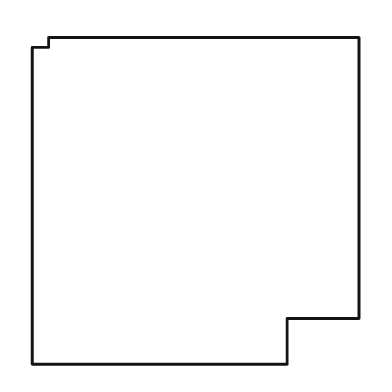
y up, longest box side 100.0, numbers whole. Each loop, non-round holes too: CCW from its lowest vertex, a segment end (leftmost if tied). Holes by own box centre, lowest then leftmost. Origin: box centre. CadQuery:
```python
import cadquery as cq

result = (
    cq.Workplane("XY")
    .moveTo(-50.0, -50.0)
    .lineTo(28.0, -50.0)
    .lineTo(28.0, -36.0)
    .lineTo(50.0, -36.0)
    .lineTo(50.0, 50.0)
    .lineTo(-45.0, 50.0)
    .lineTo(-45.0, 47.0)
    .lineTo(-50.0, 47.0)
    .close()
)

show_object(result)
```